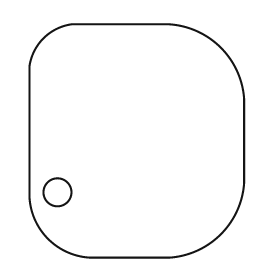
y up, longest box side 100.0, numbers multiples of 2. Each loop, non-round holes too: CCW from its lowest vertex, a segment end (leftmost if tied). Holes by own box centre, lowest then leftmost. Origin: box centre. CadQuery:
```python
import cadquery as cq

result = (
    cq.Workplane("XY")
    .moveTo(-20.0, -50.0)
    .lineTo(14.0, -50.0)
    .threePointArc((36.0, -40.0), (46.0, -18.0))
    .lineTo(46.0, 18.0)
    .threePointArc((36.0, 40.0), (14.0, 50.0))
    .lineTo(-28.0, 50.0)
    .threePointArc((-40.0, 44.0), (-46.0, 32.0))
    .lineTo(-46.0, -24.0)
    .threePointArc((-38.0, -42.0), (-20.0, -50.0))
    .close()
    .moveTo(-34.0, -22.0)
    .circle(6.0)
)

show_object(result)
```